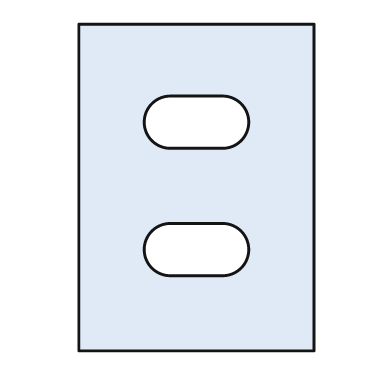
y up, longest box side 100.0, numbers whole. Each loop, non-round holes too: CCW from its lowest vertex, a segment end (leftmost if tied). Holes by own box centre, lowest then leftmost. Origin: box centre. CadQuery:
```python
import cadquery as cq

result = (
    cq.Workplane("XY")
    .moveTo(-36.0, -50.0)
    .lineTo(36.0, -50.0)
    .lineTo(36.0, 50.0)
    .lineTo(-36.0, 50.0)
    .close()
    .moveTo(-8.0, -27.0)
    .lineTo(8.0, -27.0)
    .threePointArc((16.0, -19.0), (8.0, -11.0))
    .lineTo(-8.0, -11.0)
    .threePointArc((-16.0, -19.0), (-8.0, -27.0))
    .close()
    .moveTo(-8.0, 12.0)
    .lineTo(8.0, 12.0)
    .threePointArc((16.0, 20.0), (8.0, 28.0))
    .lineTo(-8.0, 28.0)
    .threePointArc((-16.0, 20.0), (-8.0, 12.0))
    .close()
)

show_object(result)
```